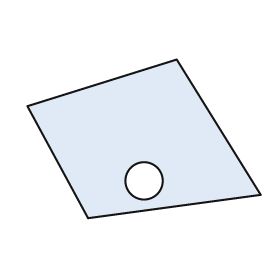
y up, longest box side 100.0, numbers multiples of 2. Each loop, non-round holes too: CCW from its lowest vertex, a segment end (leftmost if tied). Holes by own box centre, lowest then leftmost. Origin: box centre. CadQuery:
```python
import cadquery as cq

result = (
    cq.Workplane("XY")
    .moveTo(-24.0, -34.0)
    .lineTo(50.0, -24.0)
    .lineTo(14.0, 34.0)
    .lineTo(-50.0, 14.0)
    .close()
    .moveTo(0.0, -18.0)
    .circle(8.0)
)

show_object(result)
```